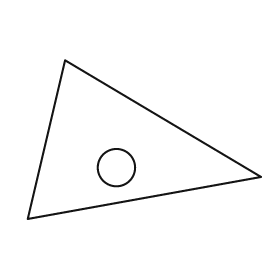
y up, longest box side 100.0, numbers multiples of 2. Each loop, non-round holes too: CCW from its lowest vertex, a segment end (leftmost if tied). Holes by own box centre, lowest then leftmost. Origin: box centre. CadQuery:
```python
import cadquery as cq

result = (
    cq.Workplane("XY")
    .moveTo(-50.0, -34.0)
    .lineTo(50.0, -16.0)
    .lineTo(-34.0, 34.0)
    .close()
    .moveTo(-12.0, -12.0)
    .circle(8.0)
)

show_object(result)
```